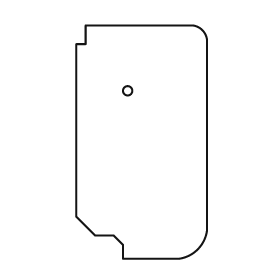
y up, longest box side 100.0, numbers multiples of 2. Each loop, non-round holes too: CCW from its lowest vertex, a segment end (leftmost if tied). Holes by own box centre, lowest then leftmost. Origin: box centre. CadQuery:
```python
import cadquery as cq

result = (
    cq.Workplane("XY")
    .moveTo(-8.0, -50.0)
    .lineTo(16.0, -50.0)
    .threePointArc((24.0, -46.0), (28.0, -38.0))
    .lineTo(28.0, 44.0)
    .threePointArc((26.0, 48.0), (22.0, 50.0))
    .lineTo(-24.0, 50.0)
    .lineTo(-24.0, 42.0)
    .lineTo(-28.0, 42.0)
    .lineTo(-28.0, -32.0)
    .lineTo(-20.0, -40.0)
    .lineTo(-12.0, -40.0)
    .lineTo(-8.0, -44.0)
    .close()
    .moveTo(-6.0, 22.0)
    .circle(2.0)
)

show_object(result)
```